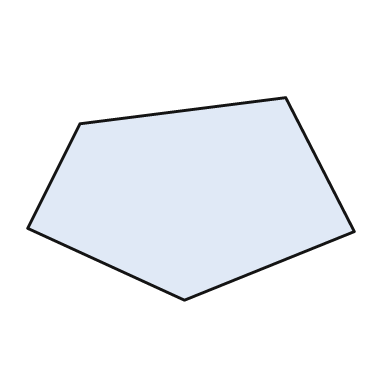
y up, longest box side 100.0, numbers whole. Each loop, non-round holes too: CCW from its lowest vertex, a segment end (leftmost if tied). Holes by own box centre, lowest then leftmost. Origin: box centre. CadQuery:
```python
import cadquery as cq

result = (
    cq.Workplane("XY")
    .moveTo(-2.0, -31.0)
    .lineTo(50.0, -10.0)
    .lineTo(29.0, 31.0)
    .lineTo(-34.0, 23.0)
    .lineTo(-50.0, -9.0)
    .close()
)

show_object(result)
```